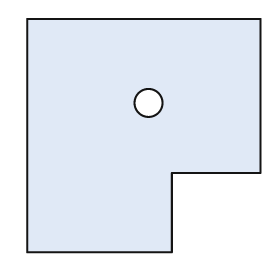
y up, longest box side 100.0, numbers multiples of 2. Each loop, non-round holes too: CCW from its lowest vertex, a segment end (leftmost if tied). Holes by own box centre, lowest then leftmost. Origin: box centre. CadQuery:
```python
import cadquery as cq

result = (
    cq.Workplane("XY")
    .moveTo(-50.0, -50.0)
    .lineTo(12.0, -50.0)
    .lineTo(12.0, -16.0)
    .lineTo(50.0, -16.0)
    .lineTo(50.0, 50.0)
    .lineTo(-50.0, 50.0)
    .close()
    .moveTo(2.0, 14.0)
    .circle(6.0)
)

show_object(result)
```